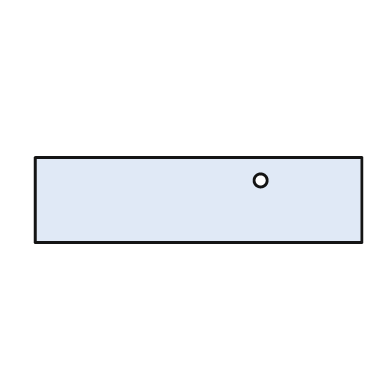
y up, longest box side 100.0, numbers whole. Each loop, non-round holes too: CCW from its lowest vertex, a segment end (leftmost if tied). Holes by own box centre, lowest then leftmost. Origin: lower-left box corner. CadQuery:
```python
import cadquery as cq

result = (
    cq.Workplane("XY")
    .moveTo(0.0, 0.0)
    .lineTo(100.0, 0.0)
    .lineTo(100.0, 26.0)
    .lineTo(0.0, 26.0)
    .close()
    .moveTo(69.0, 19.0)
    .circle(2.0)
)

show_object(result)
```